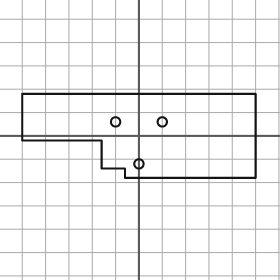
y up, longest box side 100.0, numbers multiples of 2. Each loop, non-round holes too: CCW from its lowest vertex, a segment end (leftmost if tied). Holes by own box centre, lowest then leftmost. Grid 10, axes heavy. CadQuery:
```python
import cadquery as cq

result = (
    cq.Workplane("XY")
    .moveTo(-6.0, -18.0)
    .lineTo(50.0, -18.0)
    .lineTo(50.0, 18.0)
    .lineTo(-50.0, 18.0)
    .lineTo(-50.0, -2.0)
    .lineTo(-16.0, -2.0)
    .lineTo(-16.0, -14.0)
    .lineTo(-6.0, -14.0)
    .close()
    .moveTo(0.0, -12.0)
    .circle(2.0)
    .moveTo(-10.0, 6.0)
    .circle(2.0)
    .moveTo(10.0, 6.0)
    .circle(2.0)
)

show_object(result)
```